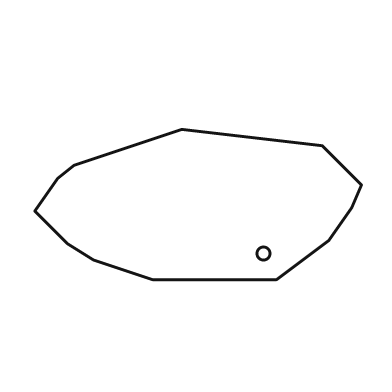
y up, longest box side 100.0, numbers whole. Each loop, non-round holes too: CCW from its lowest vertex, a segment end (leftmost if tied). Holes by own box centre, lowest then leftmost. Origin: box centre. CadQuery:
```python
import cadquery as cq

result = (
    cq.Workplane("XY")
    .moveTo(-14.0, -23.0)
    .lineTo(24.0, -23.0)
    .lineTo(40.0, -11.0)
    .lineTo(47.0, -1.0)
    .lineTo(50.0, 6.0)
    .lineTo(38.0, 18.0)
    .lineTo(-5.0, 23.0)
    .lineTo(-38.0, 12.0)
    .lineTo(-43.0, 8.0)
    .lineTo(-50.0, -2.0)
    .lineTo(-40.0, -12.0)
    .lineTo(-32.0, -17.0)
    .close()
    .moveTo(20.0, -15.0)
    .circle(2.0)
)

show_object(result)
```